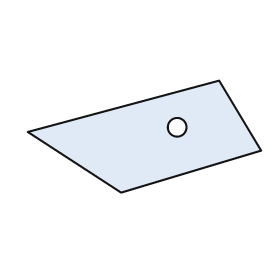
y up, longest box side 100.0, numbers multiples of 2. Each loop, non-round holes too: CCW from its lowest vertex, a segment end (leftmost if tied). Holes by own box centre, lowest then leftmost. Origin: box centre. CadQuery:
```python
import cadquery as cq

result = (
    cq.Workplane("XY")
    .moveTo(-10.0, -24.0)
    .lineTo(50.0, -6.0)
    .lineTo(32.0, 24.0)
    .lineTo(-50.0, 2.0)
    .close()
    .moveTo(14.0, 4.0)
    .circle(4.0)
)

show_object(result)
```